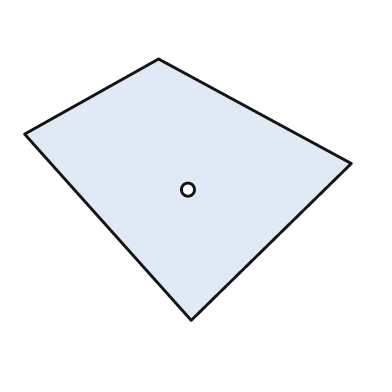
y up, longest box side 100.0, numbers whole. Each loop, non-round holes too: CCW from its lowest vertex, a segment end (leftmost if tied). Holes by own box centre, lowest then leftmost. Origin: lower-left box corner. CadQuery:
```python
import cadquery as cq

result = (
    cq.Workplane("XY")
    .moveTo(51.0, 0.0)
    .lineTo(100.0, 48.0)
    .lineTo(41.0, 80.0)
    .lineTo(0.0, 57.0)
    .close()
    .moveTo(50.0, 40.0)
    .circle(2.0)
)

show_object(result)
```